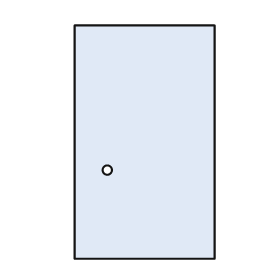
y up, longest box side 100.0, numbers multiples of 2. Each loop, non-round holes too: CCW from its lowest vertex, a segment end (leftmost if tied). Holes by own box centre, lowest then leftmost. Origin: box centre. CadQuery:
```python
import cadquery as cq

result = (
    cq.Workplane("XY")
    .moveTo(-30.0, -50.0)
    .lineTo(30.0, -50.0)
    .lineTo(30.0, 50.0)
    .lineTo(-30.0, 50.0)
    .close()
    .moveTo(-16.0, -12.0)
    .circle(2.0)
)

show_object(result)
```